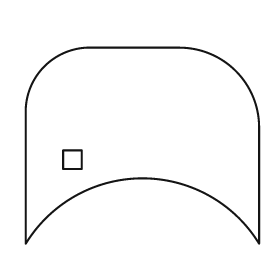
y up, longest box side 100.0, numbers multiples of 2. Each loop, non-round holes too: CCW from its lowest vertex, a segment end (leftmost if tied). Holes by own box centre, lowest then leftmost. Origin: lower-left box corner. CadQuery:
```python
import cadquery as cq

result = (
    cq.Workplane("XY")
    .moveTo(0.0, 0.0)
    .threePointArc((50.0, 28.0), (100.0, 0.0))
    .lineTo(100.0, 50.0)
    .threePointArc((90.0, 74.0), (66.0, 84.0))
    .lineTo(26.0, 84.0)
    .threePointArc((8.0, 76.0), (0.0, 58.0))
    .close()
    .moveTo(16.0, 32.0)
    .lineTo(24.0, 32.0)
    .lineTo(24.0, 40.0)
    .lineTo(16.0, 40.0)
    .close()
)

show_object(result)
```